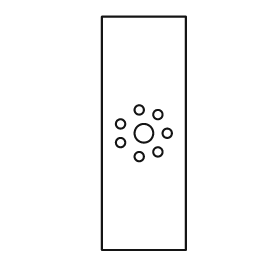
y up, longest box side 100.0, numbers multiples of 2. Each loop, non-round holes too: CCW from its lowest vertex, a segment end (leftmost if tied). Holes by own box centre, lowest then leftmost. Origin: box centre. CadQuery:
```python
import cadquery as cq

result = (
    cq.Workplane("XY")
    .moveTo(-18.0, -50.0)
    .lineTo(18.0, -50.0)
    .lineTo(18.0, 50.0)
    .lineTo(-18.0, 50.0)
    .close()
    .moveTo(-2.0, -10.0)
    .circle(2.0)
    .moveTo(6.0, -8.0)
    .circle(2.0)
    .moveTo(-10.0, -4.0)
    .circle(2.0)
    .moveTo(0.0, 0.0)
    .circle(4.0)
    .moveTo(10.0, 0.0)
    .circle(2.0)
    .moveTo(-10.0, 4.0)
    .circle(2.0)
    .moveTo(6.0, 8.0)
    .circle(2.0)
    .moveTo(-2.0, 10.0)
    .circle(2.0)
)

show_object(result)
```